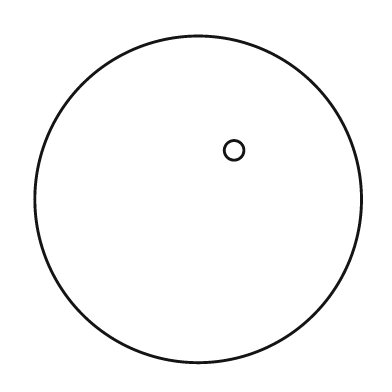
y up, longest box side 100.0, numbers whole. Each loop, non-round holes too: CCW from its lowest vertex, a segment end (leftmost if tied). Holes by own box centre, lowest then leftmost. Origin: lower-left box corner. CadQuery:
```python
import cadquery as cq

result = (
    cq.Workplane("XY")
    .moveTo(50.0, 50.0)
    .circle(50.0)
    .moveTo(61.0, 65.0)
    .circle(3.0)
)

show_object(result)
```